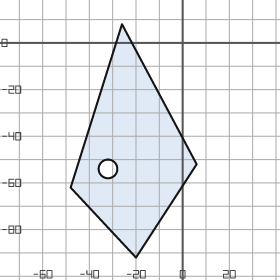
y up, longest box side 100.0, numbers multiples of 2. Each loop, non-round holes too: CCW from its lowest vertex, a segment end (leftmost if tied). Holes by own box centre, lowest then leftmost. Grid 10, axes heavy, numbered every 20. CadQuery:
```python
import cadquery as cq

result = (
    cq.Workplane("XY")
    .moveTo(-20.0, -92.0)
    .lineTo(6.0, -52.0)
    .lineTo(-26.0, 8.0)
    .lineTo(-48.0, -62.0)
    .close()
    .moveTo(-32.0, -54.0)
    .circle(4.0)
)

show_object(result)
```